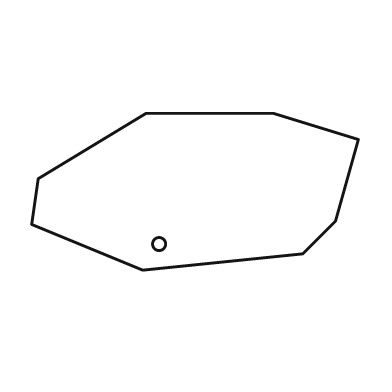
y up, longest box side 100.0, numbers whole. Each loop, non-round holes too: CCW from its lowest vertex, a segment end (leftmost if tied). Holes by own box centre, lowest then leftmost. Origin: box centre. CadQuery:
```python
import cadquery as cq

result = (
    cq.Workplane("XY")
    .moveTo(-16.0, -24.0)
    .lineTo(33.0, -19.0)
    .lineTo(43.0, -9.0)
    .lineTo(50.0, 16.0)
    .lineTo(24.0, 24.0)
    .lineTo(-15.0, 24.0)
    .lineTo(-48.0, 4.0)
    .lineTo(-50.0, -10.0)
    .close()
    .moveTo(-11.0, -16.0)
    .circle(2.0)
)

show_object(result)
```